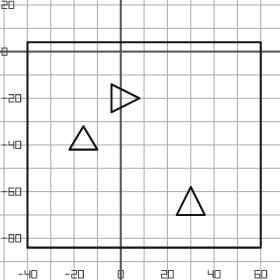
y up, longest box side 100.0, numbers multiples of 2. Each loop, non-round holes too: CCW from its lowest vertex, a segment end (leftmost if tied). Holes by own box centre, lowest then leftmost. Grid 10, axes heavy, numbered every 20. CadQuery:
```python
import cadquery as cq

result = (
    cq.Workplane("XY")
    .moveTo(-40.0, -84.0)
    .lineTo(60.0, -84.0)
    .lineTo(60.0, 4.0)
    .lineTo(-40.0, 4.0)
    .close()
    .moveTo(24.0, -70.0)
    .lineTo(36.0, -70.0)
    .lineTo(30.0, -58.0)
    .close()
    .moveTo(-22.0, -42.0)
    .lineTo(-10.0, -42.0)
    .lineTo(-16.0, -32.0)
    .close()
    .moveTo(-4.0, -26.0)
    .lineTo(8.0, -20.0)
    .lineTo(-4.0, -14.0)
    .close()
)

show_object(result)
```